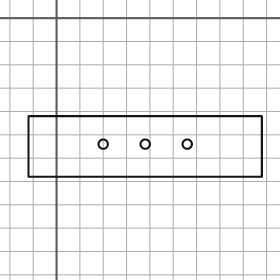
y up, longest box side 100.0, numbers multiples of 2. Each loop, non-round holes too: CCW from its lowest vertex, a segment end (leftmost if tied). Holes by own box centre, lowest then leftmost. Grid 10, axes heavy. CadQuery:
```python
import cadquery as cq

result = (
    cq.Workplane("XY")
    .moveTo(-12.0, -68.0)
    .lineTo(88.0, -68.0)
    .lineTo(88.0, -42.0)
    .lineTo(-12.0, -42.0)
    .close()
    .moveTo(20.0, -54.0)
    .circle(2.0)
    .moveTo(38.0, -54.0)
    .circle(2.0)
    .moveTo(56.0, -54.0)
    .circle(2.0)
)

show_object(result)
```